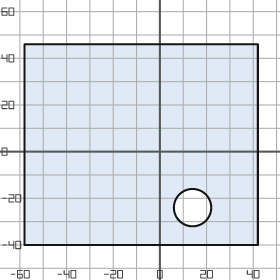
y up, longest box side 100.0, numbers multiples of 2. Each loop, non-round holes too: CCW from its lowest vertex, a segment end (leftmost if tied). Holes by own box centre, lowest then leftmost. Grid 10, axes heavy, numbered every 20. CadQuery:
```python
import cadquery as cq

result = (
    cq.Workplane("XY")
    .moveTo(-58.0, -40.0)
    .lineTo(42.0, -40.0)
    .lineTo(42.0, 46.0)
    .lineTo(-58.0, 46.0)
    .close()
    .moveTo(14.0, -24.0)
    .circle(8.0)
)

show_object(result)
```